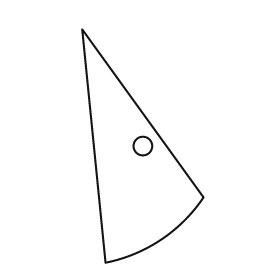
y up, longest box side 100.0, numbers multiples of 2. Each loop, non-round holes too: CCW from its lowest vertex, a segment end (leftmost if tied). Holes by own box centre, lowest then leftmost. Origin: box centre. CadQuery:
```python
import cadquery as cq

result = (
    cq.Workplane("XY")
    .moveTo(-16.0, -50.0)
    .threePointArc((8.0, -40.0), (26.0, -22.0))
    .lineTo(-26.0, 50.0)
    .close()
    .moveTo(0.0, 0.0)
    .circle(4.0)
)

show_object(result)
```